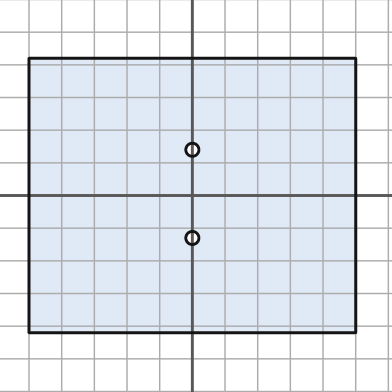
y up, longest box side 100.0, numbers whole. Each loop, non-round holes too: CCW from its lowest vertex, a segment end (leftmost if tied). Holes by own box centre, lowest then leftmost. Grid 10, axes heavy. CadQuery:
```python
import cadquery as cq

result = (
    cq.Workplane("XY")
    .moveTo(-50.0, -42.0)
    .lineTo(50.0, -42.0)
    .lineTo(50.0, 42.0)
    .lineTo(-50.0, 42.0)
    .close()
    .moveTo(0.0, -13.0)
    .circle(2.0)
    .moveTo(0.0, 14.0)
    .circle(2.0)
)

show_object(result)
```